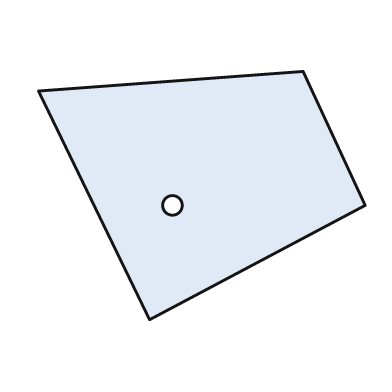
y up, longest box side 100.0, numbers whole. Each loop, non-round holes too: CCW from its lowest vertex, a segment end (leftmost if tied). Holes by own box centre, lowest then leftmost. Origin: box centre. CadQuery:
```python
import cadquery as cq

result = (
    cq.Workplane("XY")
    .moveTo(-16.0, -38.0)
    .lineTo(50.0, -3.0)
    .lineTo(31.0, 38.0)
    .lineTo(-50.0, 32.0)
    .close()
    .moveTo(-9.0, -3.0)
    .circle(3.0)
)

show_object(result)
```